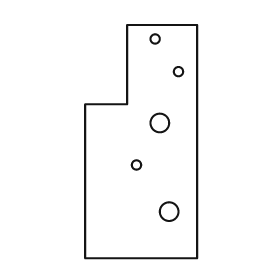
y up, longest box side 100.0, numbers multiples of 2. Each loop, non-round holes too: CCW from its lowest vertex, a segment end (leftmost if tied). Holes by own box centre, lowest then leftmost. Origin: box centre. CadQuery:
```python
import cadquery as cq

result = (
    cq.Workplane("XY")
    .moveTo(-24.0, -50.0)
    .lineTo(24.0, -50.0)
    .lineTo(24.0, 50.0)
    .lineTo(-6.0, 50.0)
    .lineTo(-6.0, 16.0)
    .lineTo(-24.0, 16.0)
    .close()
    .moveTo(12.0, -30.0)
    .circle(4.0)
    .moveTo(-2.0, -10.0)
    .circle(2.0)
    .moveTo(8.0, 8.0)
    .circle(4.0)
    .moveTo(16.0, 30.0)
    .circle(2.0)
    .moveTo(6.0, 44.0)
    .circle(2.0)
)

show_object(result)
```